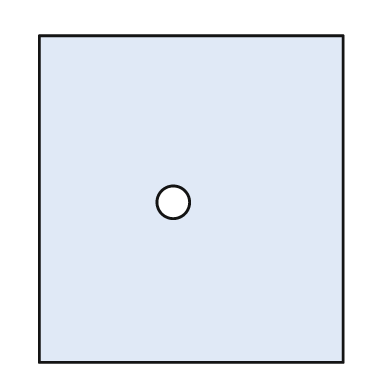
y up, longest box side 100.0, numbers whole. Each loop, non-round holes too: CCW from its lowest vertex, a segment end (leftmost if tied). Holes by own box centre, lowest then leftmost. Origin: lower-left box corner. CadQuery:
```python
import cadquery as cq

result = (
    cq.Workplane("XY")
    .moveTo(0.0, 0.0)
    .lineTo(93.0, 0.0)
    .lineTo(93.0, 100.0)
    .lineTo(0.0, 100.0)
    .close()
    .moveTo(41.0, 49.0)
    .circle(5.0)
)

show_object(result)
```